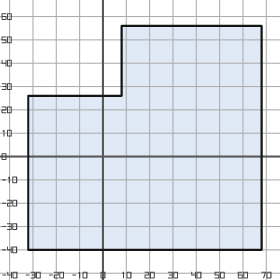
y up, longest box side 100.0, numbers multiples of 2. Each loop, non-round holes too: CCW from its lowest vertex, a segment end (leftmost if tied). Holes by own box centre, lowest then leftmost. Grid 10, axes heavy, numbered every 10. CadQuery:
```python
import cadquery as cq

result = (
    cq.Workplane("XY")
    .moveTo(-32.0, -40.0)
    .lineTo(68.0, -40.0)
    .lineTo(68.0, 56.0)
    .lineTo(8.0, 56.0)
    .lineTo(8.0, 26.0)
    .lineTo(-32.0, 26.0)
    .close()
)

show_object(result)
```